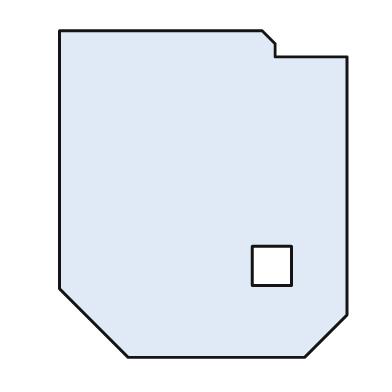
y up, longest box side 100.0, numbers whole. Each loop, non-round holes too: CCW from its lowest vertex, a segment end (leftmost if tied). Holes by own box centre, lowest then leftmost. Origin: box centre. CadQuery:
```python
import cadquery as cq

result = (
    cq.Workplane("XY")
    .moveTo(-23.0, -50.0)
    .lineTo(31.0, -50.0)
    .lineTo(44.0, -37.0)
    .lineTo(44.0, 42.0)
    .lineTo(22.0, 42.0)
    .lineTo(22.0, 46.0)
    .lineTo(18.0, 50.0)
    .lineTo(-44.0, 50.0)
    .lineTo(-44.0, -29.0)
    .close()
    .moveTo(15.0, -28.0)
    .lineTo(27.0, -28.0)
    .lineTo(27.0, -16.0)
    .lineTo(15.0, -16.0)
    .close()
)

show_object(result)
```